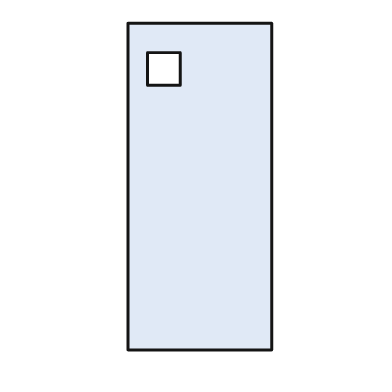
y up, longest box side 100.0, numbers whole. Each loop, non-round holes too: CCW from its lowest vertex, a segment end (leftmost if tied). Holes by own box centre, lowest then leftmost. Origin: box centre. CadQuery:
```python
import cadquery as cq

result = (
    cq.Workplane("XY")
    .moveTo(-22.0, -50.0)
    .lineTo(22.0, -50.0)
    .lineTo(22.0, 50.0)
    .lineTo(-22.0, 50.0)
    .close()
    .moveTo(-16.0, 31.0)
    .lineTo(-6.0, 31.0)
    .lineTo(-6.0, 41.0)
    .lineTo(-16.0, 41.0)
    .close()
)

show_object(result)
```